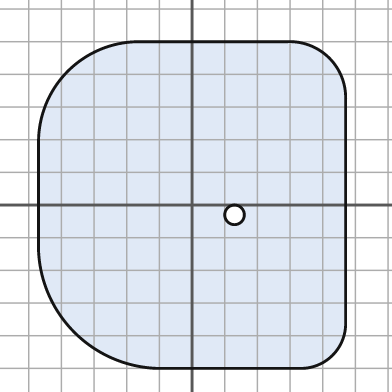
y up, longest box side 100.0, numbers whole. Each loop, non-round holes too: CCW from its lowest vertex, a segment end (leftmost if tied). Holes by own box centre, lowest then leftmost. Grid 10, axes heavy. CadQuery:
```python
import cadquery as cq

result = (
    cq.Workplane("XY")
    .moveTo(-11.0, -50.0)
    .lineTo(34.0, -50.0)
    .threePointArc((43.0, -46.0), (47.0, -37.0))
    .lineTo(47.0, 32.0)
    .threePointArc((42.0, 45.0), (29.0, 50.0))
    .lineTo(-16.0, 50.0)
    .threePointArc((-38.0, 41.0), (-47.0, 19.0))
    .lineTo(-47.0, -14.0)
    .threePointArc((-36.0, -39.0), (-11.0, -50.0))
    .close()
    .moveTo(13.0, -3.0)
    .circle(3.0)
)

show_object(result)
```